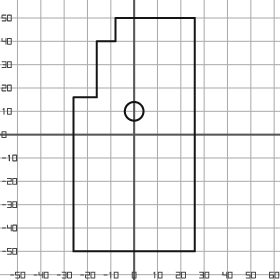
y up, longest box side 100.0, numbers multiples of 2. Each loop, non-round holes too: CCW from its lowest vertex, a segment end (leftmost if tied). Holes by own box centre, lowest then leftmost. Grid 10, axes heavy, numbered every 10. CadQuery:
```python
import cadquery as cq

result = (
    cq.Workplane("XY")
    .moveTo(-26.0, -50.0)
    .lineTo(26.0, -50.0)
    .lineTo(26.0, 50.0)
    .lineTo(-8.0, 50.0)
    .lineTo(-8.0, 40.0)
    .lineTo(-16.0, 40.0)
    .lineTo(-16.0, 16.0)
    .lineTo(-26.0, 16.0)
    .close()
    .moveTo(0.0, 10.0)
    .circle(4.0)
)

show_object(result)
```